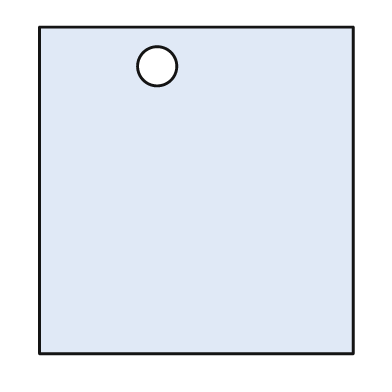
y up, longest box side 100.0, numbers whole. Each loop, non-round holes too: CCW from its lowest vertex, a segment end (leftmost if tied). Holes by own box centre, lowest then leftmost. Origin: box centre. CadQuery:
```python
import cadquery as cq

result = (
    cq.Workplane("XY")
    .moveTo(-48.0, -50.0)
    .lineTo(48.0, -50.0)
    .lineTo(48.0, 50.0)
    .lineTo(-48.0, 50.0)
    .close()
    .moveTo(-12.0, 38.0)
    .circle(6.0)
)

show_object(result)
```